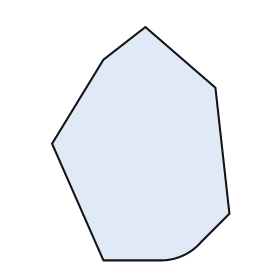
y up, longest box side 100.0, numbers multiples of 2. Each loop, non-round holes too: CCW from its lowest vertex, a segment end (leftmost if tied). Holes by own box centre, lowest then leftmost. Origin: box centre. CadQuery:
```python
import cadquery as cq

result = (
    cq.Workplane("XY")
    .moveTo(-16.0, -50.0)
    .lineTo(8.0, -50.0)
    .threePointArc((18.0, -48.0), (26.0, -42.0))
    .lineTo(38.0, -30.0)
    .lineTo(32.0, 24.0)
    .lineTo(2.0, 50.0)
    .lineTo(-16.0, 36.0)
    .lineTo(-38.0, 0.0)
    .close()
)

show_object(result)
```